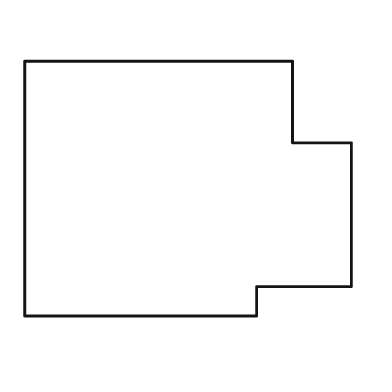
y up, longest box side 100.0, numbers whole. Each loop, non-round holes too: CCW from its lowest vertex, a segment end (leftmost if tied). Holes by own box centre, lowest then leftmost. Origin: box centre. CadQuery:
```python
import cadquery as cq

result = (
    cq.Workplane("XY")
    .moveTo(-50.0, -39.0)
    .lineTo(21.0, -39.0)
    .lineTo(21.0, -30.0)
    .lineTo(50.0, -30.0)
    .lineTo(50.0, 14.0)
    .lineTo(32.0, 14.0)
    .lineTo(32.0, 39.0)
    .lineTo(-50.0, 39.0)
    .close()
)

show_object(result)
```